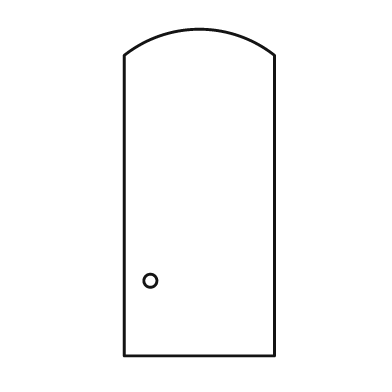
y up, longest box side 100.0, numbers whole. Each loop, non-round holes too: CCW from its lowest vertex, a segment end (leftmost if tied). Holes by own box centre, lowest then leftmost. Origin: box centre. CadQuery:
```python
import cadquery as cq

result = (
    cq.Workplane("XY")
    .moveTo(-23.0, -50.0)
    .lineTo(23.0, -50.0)
    .lineTo(23.0, 42.0)
    .threePointArc((0.0, 50.0), (-23.0, 42.0))
    .close()
    .moveTo(-15.0, -27.0)
    .circle(2.0)
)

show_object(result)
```